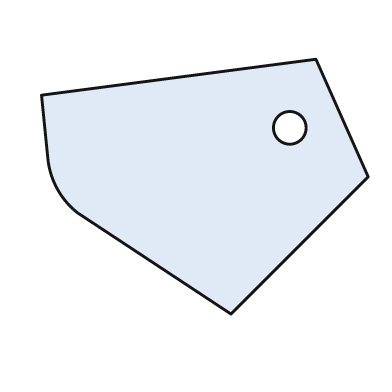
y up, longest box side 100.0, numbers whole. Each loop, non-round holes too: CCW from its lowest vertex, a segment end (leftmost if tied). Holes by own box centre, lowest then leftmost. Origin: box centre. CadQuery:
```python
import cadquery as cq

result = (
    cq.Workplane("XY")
    .moveTo(8.0, -39.0)
    .lineTo(50.0, 3.0)
    .lineTo(34.0, 39.0)
    .lineTo(-50.0, 28.0)
    .lineTo(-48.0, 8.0)
    .threePointArc((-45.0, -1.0), (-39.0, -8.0))
    .close()
    .moveTo(26.0, 18.0)
    .circle(5.0)
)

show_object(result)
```